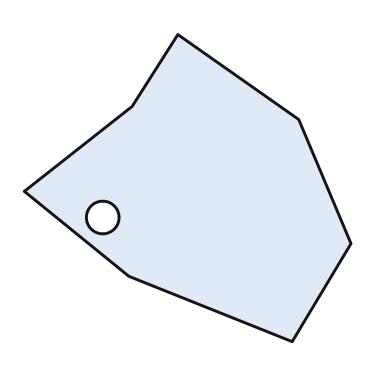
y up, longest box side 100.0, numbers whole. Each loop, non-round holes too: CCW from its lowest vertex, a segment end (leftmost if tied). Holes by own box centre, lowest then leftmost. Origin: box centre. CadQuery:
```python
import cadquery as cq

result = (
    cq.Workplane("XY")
    .moveTo(32.0, -47.0)
    .lineTo(50.0, -17.0)
    .lineTo(34.0, 21.0)
    .lineTo(-3.0, 47.0)
    .lineTo(-17.0, 25.0)
    .lineTo(-50.0, -1.0)
    .lineTo(-18.0, -27.0)
    .close()
    .moveTo(-26.0, -9.0)
    .circle(5.0)
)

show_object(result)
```